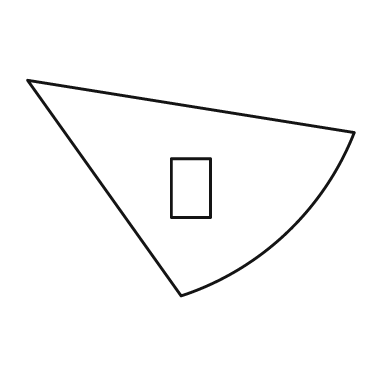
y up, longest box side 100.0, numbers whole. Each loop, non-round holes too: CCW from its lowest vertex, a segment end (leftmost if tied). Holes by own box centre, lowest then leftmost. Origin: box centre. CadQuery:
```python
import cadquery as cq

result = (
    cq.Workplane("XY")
    .moveTo(-3.0, -33.0)
    .threePointArc((29.0, -14.0), (50.0, 17.0))
    .lineTo(-50.0, 33.0)
    .close()
    .moveTo(-6.0, -9.0)
    .lineTo(6.0, -9.0)
    .lineTo(6.0, 9.0)
    .lineTo(-6.0, 9.0)
    .close()
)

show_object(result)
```